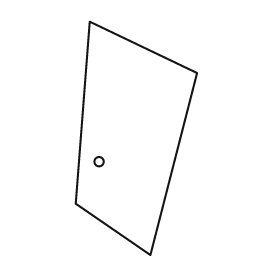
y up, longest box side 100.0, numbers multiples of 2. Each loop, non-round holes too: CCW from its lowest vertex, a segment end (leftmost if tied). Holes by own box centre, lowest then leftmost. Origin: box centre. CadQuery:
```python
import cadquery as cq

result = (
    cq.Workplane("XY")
    .moveTo(6.0, -50.0)
    .lineTo(26.0, 28.0)
    .lineTo(-20.0, 50.0)
    .lineTo(-26.0, -28.0)
    .close()
    .moveTo(-16.0, -10.0)
    .circle(2.0)
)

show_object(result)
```